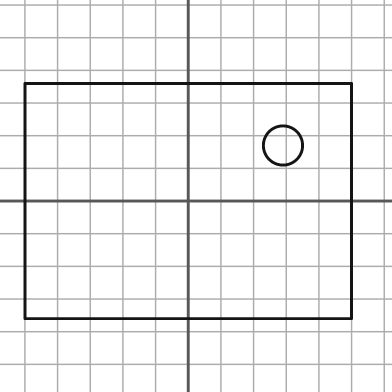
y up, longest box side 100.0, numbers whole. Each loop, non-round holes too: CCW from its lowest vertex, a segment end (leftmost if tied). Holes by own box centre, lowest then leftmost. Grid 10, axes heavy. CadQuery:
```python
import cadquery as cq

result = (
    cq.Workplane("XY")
    .moveTo(-50.0, -36.0)
    .lineTo(50.0, -36.0)
    .lineTo(50.0, 36.0)
    .lineTo(-50.0, 36.0)
    .close()
    .moveTo(29.0, 17.0)
    .circle(6.0)
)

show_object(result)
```